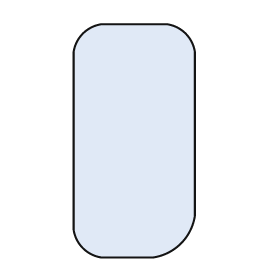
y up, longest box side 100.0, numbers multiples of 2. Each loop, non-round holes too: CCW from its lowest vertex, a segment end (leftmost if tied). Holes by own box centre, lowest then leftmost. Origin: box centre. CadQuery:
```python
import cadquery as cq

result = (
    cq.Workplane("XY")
    .moveTo(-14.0, -50.0)
    .lineTo(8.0, -50.0)
    .threePointArc((20.0, -44.0), (26.0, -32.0))
    .lineTo(26.0, 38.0)
    .threePointArc((22.0, 46.0), (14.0, 50.0))
    .lineTo(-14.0, 50.0)
    .threePointArc((-22.0, 46.0), (-26.0, 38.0))
    .lineTo(-26.0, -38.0)
    .threePointArc((-22.0, -46.0), (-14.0, -50.0))
    .close()
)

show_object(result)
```